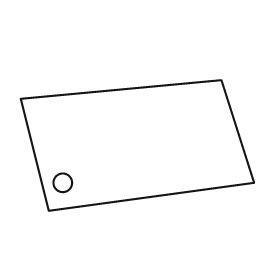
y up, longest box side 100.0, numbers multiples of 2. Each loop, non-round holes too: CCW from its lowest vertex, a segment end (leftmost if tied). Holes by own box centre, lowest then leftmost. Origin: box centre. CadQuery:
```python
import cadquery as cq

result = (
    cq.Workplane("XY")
    .moveTo(-38.0, -28.0)
    .lineTo(50.0, -16.0)
    .lineTo(36.0, 28.0)
    .lineTo(-50.0, 20.0)
    .close()
    .moveTo(-32.0, -16.0)
    .circle(4.0)
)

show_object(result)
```